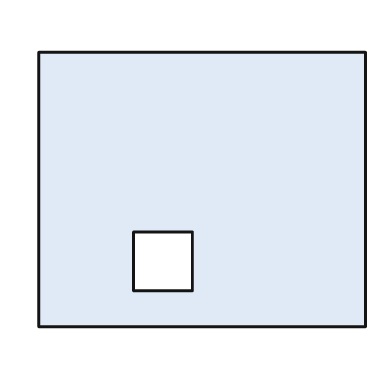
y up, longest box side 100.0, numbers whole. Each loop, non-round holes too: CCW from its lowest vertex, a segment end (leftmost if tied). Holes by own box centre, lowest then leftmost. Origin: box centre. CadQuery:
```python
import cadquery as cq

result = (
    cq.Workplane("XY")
    .moveTo(-50.0, -42.0)
    .lineTo(50.0, -42.0)
    .lineTo(50.0, 42.0)
    .lineTo(-50.0, 42.0)
    .close()
    .moveTo(-21.0, -31.0)
    .lineTo(-3.0, -31.0)
    .lineTo(-3.0, -13.0)
    .lineTo(-21.0, -13.0)
    .close()
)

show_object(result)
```